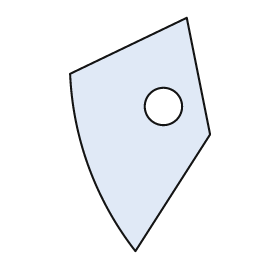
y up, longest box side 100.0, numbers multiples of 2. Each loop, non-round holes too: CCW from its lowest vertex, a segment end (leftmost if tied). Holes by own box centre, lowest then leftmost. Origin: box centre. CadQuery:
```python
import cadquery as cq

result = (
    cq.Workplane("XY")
    .moveTo(-2.0, -50.0)
    .lineTo(30.0, 0.0)
    .lineTo(20.0, 50.0)
    .lineTo(-30.0, 26.0)
    .threePointArc((-22.0, -14.0), (-2.0, -50.0))
    .close()
    .moveTo(10.0, 12.0)
    .circle(8.0)
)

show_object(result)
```